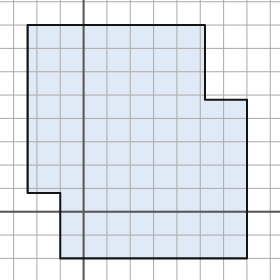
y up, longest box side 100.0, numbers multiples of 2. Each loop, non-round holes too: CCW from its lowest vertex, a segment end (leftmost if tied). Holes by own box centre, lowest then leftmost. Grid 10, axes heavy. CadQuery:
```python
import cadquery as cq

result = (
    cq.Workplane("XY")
    .moveTo(-10.0, -20.0)
    .lineTo(70.0, -20.0)
    .lineTo(70.0, 48.0)
    .lineTo(52.0, 48.0)
    .lineTo(52.0, 80.0)
    .lineTo(-24.0, 80.0)
    .lineTo(-24.0, 8.0)
    .lineTo(-10.0, 8.0)
    .close()
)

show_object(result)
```